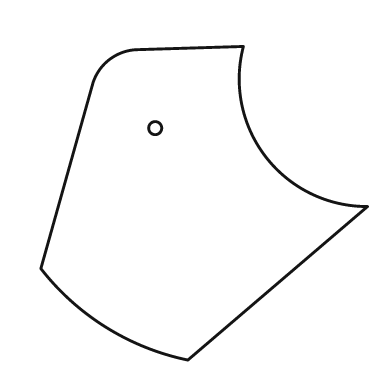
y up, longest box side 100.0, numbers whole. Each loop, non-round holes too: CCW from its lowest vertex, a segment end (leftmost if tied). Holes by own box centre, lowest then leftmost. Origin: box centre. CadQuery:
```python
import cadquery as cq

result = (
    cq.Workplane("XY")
    .moveTo(-5.0, -48.0)
    .lineTo(50.0, -1.0)
    .threePointArc((19.0, 14.0), (12.0, 48.0))
    .lineTo(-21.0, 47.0)
    .threePointArc((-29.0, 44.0), (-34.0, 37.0))
    .lineTo(-50.0, -20.0)
    .threePointArc((-30.0, -38.0), (-5.0, -48.0))
    .close()
    .moveTo(-15.0, 23.0)
    .circle(2.0)
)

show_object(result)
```